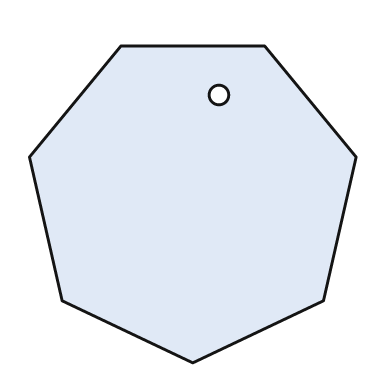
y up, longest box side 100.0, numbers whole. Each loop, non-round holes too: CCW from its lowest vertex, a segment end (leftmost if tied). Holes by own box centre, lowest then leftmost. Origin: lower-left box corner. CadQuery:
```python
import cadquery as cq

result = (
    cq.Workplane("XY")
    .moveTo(50.0, 0.0)
    .lineTo(90.0, 19.0)
    .lineTo(100.0, 63.0)
    .lineTo(72.0, 97.0)
    .lineTo(28.0, 97.0)
    .lineTo(0.0, 63.0)
    .lineTo(10.0, 19.0)
    .close()
    .moveTo(58.0, 82.0)
    .circle(3.0)
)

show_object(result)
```